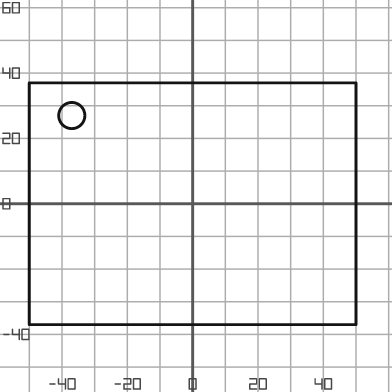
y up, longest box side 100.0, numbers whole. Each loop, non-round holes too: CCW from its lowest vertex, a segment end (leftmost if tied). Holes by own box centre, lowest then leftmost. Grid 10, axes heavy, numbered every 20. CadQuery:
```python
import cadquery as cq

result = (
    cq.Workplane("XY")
    .moveTo(-50.0, -37.0)
    .lineTo(50.0, -37.0)
    .lineTo(50.0, 37.0)
    .lineTo(-50.0, 37.0)
    .close()
    .moveTo(-37.0, 27.0)
    .circle(4.0)
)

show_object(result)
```